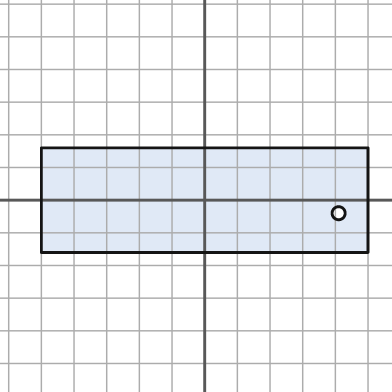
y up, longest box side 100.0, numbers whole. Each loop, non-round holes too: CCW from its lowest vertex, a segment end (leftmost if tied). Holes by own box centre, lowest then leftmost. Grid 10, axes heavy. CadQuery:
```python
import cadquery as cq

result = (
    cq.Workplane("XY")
    .moveTo(-50.0, -16.0)
    .lineTo(50.0, -16.0)
    .lineTo(50.0, 16.0)
    .lineTo(-50.0, 16.0)
    .close()
    .moveTo(41.0, -4.0)
    .circle(2.0)
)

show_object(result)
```